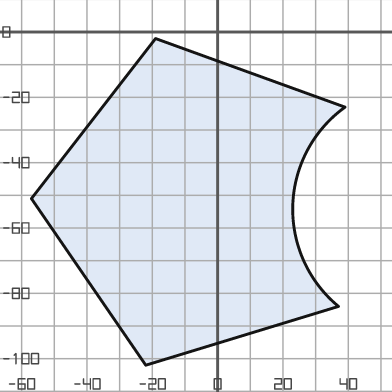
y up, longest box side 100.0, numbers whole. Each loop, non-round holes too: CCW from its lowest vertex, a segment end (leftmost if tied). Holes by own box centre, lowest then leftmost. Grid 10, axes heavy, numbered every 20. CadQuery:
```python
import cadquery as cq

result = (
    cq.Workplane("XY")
    .moveTo(-22.0, -102.0)
    .lineTo(37.0, -84.0)
    .threePointArc((23.0, -53.0), (39.0, -23.0))
    .lineTo(-19.0, -2.0)
    .lineTo(-57.0, -51.0)
    .close()
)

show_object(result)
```